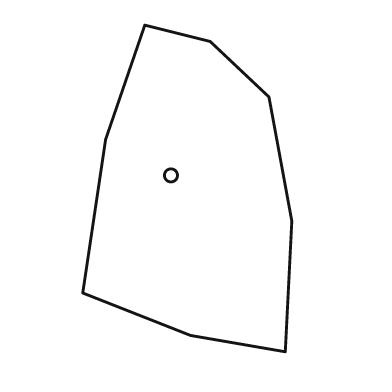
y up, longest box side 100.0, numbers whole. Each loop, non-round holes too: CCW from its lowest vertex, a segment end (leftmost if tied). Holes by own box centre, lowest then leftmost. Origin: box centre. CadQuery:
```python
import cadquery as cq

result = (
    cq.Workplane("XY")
    .moveTo(30.0, -50.0)
    .lineTo(32.0, -10.0)
    .lineTo(25.0, 28.0)
    .lineTo(7.0, 45.0)
    .lineTo(-13.0, 50.0)
    .lineTo(-25.0, 15.0)
    .lineTo(-32.0, -32.0)
    .lineTo(1.0, -45.0)
    .close()
    .moveTo(-5.0, 4.0)
    .circle(2.0)
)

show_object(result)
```